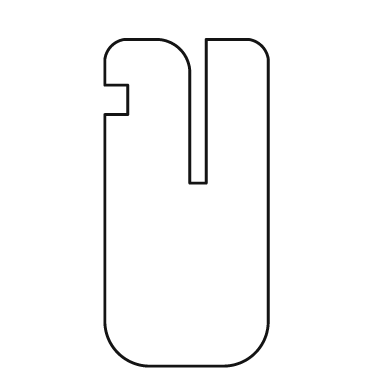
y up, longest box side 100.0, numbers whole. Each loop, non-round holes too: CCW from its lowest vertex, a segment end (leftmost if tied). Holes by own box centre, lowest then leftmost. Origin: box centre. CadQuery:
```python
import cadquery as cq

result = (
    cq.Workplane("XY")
    .moveTo(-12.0, -50.0)
    .lineTo(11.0, -50.0)
    .threePointArc((21.0, -46.0), (25.0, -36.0))
    .lineTo(25.0, 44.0)
    .threePointArc((23.0, 48.0), (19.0, 50.0))
    .lineTo(6.0, 50.0)
    .lineTo(6.0, 6.0)
    .lineTo(1.0, 6.0)
    .lineTo(1.0, 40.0)
    .threePointArc((-2.0, 47.0), (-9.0, 50.0))
    .lineTo(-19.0, 50.0)
    .threePointArc((-23.0, 48.0), (-25.0, 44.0))
    .lineTo(-25.0, 36.0)
    .lineTo(-18.0, 36.0)
    .lineTo(-18.0, 27.0)
    .lineTo(-25.0, 27.0)
    .lineTo(-25.0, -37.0)
    .threePointArc((-21.0, -46.0), (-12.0, -50.0))
    .close()
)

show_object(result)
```